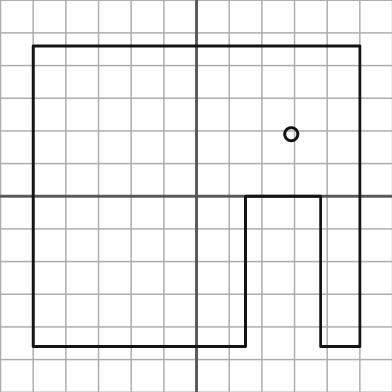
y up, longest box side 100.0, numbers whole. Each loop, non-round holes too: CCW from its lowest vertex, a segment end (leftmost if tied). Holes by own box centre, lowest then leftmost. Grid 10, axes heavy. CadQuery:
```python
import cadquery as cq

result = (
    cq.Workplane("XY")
    .moveTo(-50.0, -46.0)
    .lineTo(15.0, -46.0)
    .lineTo(15.0, 0.0)
    .lineTo(38.0, 0.0)
    .lineTo(38.0, -46.0)
    .lineTo(50.0, -46.0)
    .lineTo(50.0, 46.0)
    .lineTo(-50.0, 46.0)
    .close()
    .moveTo(29.0, 19.0)
    .circle(2.0)
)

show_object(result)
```